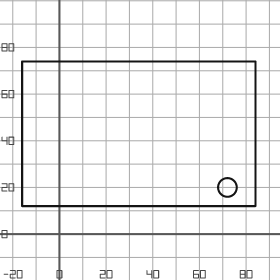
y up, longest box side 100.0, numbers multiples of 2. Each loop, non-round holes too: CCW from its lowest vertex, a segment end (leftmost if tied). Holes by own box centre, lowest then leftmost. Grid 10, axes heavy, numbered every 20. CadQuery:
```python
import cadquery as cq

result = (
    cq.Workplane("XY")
    .moveTo(-16.0, 12.0)
    .lineTo(84.0, 12.0)
    .lineTo(84.0, 74.0)
    .lineTo(-16.0, 74.0)
    .close()
    .moveTo(72.0, 20.0)
    .circle(4.0)
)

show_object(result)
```